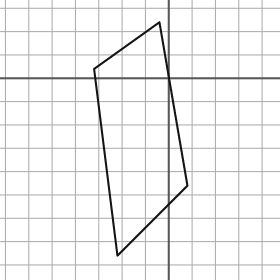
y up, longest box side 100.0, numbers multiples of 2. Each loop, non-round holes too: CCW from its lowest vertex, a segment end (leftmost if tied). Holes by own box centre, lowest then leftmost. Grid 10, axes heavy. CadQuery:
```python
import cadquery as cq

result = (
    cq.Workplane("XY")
    .moveTo(-22.0, -76.0)
    .lineTo(8.0, -46.0)
    .lineTo(-4.0, 24.0)
    .lineTo(-32.0, 4.0)
    .close()
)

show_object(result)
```